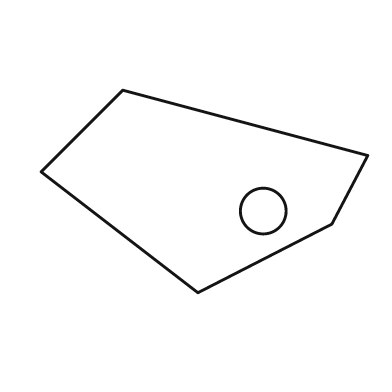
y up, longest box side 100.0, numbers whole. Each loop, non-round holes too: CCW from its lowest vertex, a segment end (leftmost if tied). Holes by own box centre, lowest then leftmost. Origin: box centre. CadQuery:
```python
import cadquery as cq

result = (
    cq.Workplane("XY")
    .moveTo(-2.0, -31.0)
    .lineTo(39.0, -10.0)
    .lineTo(50.0, 11.0)
    .lineTo(-25.0, 31.0)
    .lineTo(-50.0, 6.0)
    .close()
    .moveTo(18.0, -6.0)
    .circle(7.0)
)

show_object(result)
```